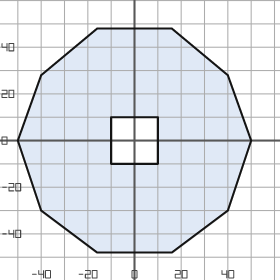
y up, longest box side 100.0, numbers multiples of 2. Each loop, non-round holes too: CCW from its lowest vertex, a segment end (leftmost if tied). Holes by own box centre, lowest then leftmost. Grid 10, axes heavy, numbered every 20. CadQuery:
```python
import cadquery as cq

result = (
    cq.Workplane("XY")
    .moveTo(-16.0, -48.0)
    .lineTo(16.0, -48.0)
    .lineTo(40.0, -30.0)
    .lineTo(50.0, 0.0)
    .lineTo(40.0, 28.0)
    .lineTo(16.0, 48.0)
    .lineTo(-16.0, 48.0)
    .lineTo(-40.0, 28.0)
    .lineTo(-50.0, 0.0)
    .lineTo(-40.0, -30.0)
    .close()
    .moveTo(-10.0, -10.0)
    .lineTo(10.0, -10.0)
    .lineTo(10.0, 10.0)
    .lineTo(-10.0, 10.0)
    .close()
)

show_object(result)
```